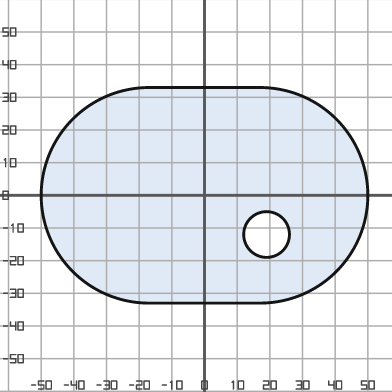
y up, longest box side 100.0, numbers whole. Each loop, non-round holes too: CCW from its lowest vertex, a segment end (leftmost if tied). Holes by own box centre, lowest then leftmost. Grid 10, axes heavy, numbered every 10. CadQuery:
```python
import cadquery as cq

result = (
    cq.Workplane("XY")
    .moveTo(-17.0, -33.0)
    .lineTo(17.0, -33.0)
    .threePointArc((50.0, 0.0), (17.0, 33.0))
    .lineTo(-17.0, 33.0)
    .threePointArc((-50.0, 0.0), (-17.0, -33.0))
    .close()
    .moveTo(19.0, -12.0)
    .circle(7.0)
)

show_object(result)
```